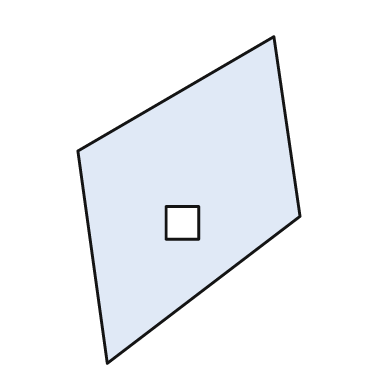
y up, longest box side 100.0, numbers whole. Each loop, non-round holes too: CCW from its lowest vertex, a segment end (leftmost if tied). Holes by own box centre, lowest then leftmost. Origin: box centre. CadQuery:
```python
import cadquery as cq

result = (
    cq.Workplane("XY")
    .moveTo(-25.0, -50.0)
    .lineTo(34.0, -5.0)
    .lineTo(26.0, 50.0)
    .lineTo(-34.0, 15.0)
    .close()
    .moveTo(-7.0, -12.0)
    .lineTo(3.0, -12.0)
    .lineTo(3.0, -2.0)
    .lineTo(-7.0, -2.0)
    .close()
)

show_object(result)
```